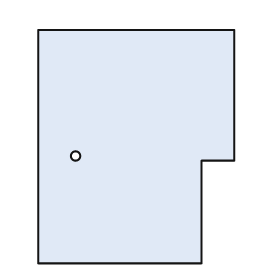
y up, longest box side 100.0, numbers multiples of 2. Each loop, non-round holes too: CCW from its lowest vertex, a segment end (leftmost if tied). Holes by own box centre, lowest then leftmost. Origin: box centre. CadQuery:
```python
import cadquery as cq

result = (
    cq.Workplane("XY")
    .moveTo(-42.0, -50.0)
    .lineTo(28.0, -50.0)
    .lineTo(28.0, -6.0)
    .lineTo(42.0, -6.0)
    .lineTo(42.0, 50.0)
    .lineTo(-42.0, 50.0)
    .close()
    .moveTo(-26.0, -4.0)
    .circle(2.0)
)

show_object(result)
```